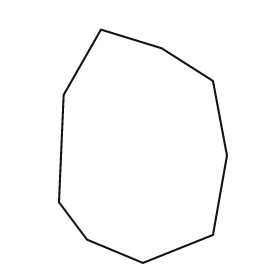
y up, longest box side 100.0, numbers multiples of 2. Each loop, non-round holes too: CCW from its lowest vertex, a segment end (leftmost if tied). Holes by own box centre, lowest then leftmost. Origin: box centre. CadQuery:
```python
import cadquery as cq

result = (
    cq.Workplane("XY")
    .moveTo(0.0, -50.0)
    .lineTo(30.0, -38.0)
    .lineTo(36.0, -4.0)
    .lineTo(30.0, 28.0)
    .lineTo(8.0, 42.0)
    .lineTo(-18.0, 50.0)
    .lineTo(-34.0, 22.0)
    .lineTo(-36.0, -24.0)
    .lineTo(-24.0, -40.0)
    .close()
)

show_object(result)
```